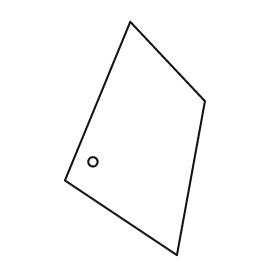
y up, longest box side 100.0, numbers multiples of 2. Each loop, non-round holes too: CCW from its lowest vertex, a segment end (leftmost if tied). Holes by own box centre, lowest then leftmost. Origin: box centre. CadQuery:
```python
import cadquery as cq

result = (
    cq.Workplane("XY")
    .moveTo(18.0, -50.0)
    .lineTo(30.0, 16.0)
    .lineTo(-2.0, 50.0)
    .lineTo(-30.0, -18.0)
    .close()
    .moveTo(-18.0, -10.0)
    .circle(2.0)
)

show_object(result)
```